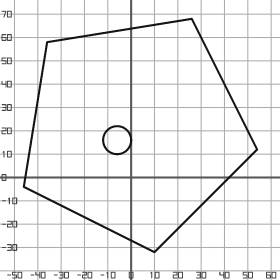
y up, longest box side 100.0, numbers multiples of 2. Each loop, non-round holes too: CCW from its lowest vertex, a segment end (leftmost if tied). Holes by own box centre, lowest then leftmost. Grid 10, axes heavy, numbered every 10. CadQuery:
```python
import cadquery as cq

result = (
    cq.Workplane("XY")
    .moveTo(10.0, -32.0)
    .lineTo(54.0, 12.0)
    .lineTo(26.0, 68.0)
    .lineTo(-36.0, 58.0)
    .lineTo(-46.0, -4.0)
    .close()
    .moveTo(-6.0, 16.0)
    .circle(6.0)
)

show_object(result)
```